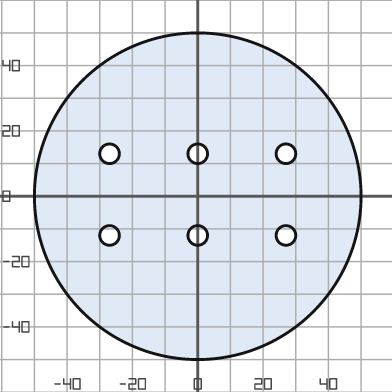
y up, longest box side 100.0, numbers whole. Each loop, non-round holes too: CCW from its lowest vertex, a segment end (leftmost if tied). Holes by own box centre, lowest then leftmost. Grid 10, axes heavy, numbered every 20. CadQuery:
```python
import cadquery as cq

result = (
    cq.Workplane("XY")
    .moveTo(0.0, 0.0)
    .circle(50.0)
    .moveTo(-27.0, -12.0)
    .circle(3.0)
    .moveTo(0.0, -12.0)
    .circle(3.0)
    .moveTo(27.0, -12.0)
    .circle(3.0)
    .moveTo(-27.0, 13.0)
    .circle(3.0)
    .moveTo(0.0, 13.0)
    .circle(3.0)
    .moveTo(27.0, 13.0)
    .circle(3.0)
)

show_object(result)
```